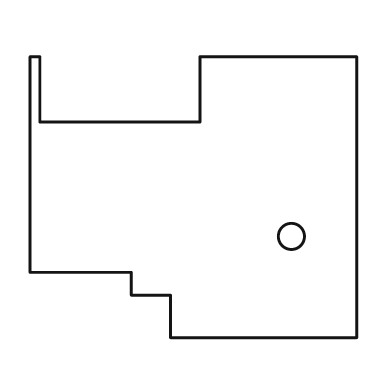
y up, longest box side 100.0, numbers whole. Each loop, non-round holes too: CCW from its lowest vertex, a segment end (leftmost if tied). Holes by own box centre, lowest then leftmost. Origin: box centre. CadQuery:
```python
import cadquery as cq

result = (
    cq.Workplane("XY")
    .moveTo(-7.0, -43.0)
    .lineTo(50.0, -43.0)
    .lineTo(50.0, 43.0)
    .lineTo(2.0, 43.0)
    .lineTo(2.0, 23.0)
    .lineTo(-47.0, 23.0)
    .lineTo(-47.0, 43.0)
    .lineTo(-50.0, 43.0)
    .lineTo(-50.0, -23.0)
    .lineTo(-19.0, -23.0)
    .lineTo(-19.0, -30.0)
    .lineTo(-7.0, -30.0)
    .close()
    .moveTo(30.0, -12.0)
    .circle(4.0)
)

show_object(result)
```